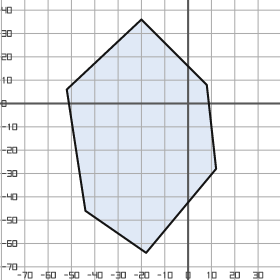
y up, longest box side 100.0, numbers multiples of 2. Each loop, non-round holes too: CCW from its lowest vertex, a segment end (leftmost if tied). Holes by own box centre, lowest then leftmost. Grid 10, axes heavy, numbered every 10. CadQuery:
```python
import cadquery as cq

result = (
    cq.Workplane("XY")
    .moveTo(-18.0, -64.0)
    .lineTo(12.0, -28.0)
    .lineTo(8.0, 8.0)
    .lineTo(-20.0, 36.0)
    .lineTo(-52.0, 6.0)
    .lineTo(-44.0, -46.0)
    .close()
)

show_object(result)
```